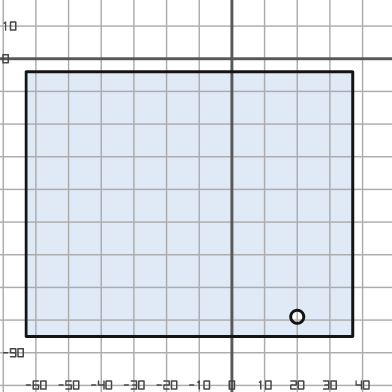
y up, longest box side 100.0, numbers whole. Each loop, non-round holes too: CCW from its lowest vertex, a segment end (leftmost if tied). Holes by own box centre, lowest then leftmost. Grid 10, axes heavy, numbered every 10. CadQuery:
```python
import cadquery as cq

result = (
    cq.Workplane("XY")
    .moveTo(-63.0, -85.0)
    .lineTo(37.0, -85.0)
    .lineTo(37.0, -4.0)
    .lineTo(-63.0, -4.0)
    .close()
    .moveTo(20.0, -79.0)
    .circle(2.0)
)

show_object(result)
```